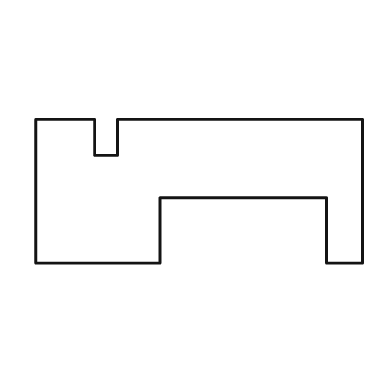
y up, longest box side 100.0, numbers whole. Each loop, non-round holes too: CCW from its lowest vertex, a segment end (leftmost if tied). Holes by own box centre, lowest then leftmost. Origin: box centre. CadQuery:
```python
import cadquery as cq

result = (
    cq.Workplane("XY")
    .moveTo(-50.0, -22.0)
    .lineTo(-12.0, -22.0)
    .lineTo(-12.0, -2.0)
    .lineTo(39.0, -2.0)
    .lineTo(39.0, -22.0)
    .lineTo(50.0, -22.0)
    .lineTo(50.0, 22.0)
    .lineTo(-25.0, 22.0)
    .lineTo(-25.0, 11.0)
    .lineTo(-32.0, 11.0)
    .lineTo(-32.0, 22.0)
    .lineTo(-50.0, 22.0)
    .close()
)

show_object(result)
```